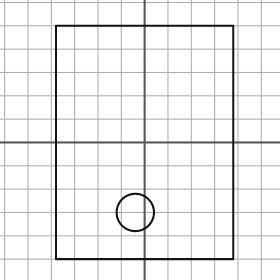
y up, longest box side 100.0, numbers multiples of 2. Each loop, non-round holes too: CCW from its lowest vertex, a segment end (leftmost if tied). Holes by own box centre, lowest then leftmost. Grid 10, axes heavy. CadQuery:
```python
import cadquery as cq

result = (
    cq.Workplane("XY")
    .moveTo(-38.0, -50.0)
    .lineTo(38.0, -50.0)
    .lineTo(38.0, 50.0)
    .lineTo(-38.0, 50.0)
    .close()
    .moveTo(-4.0, -30.0)
    .circle(8.0)
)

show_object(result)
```